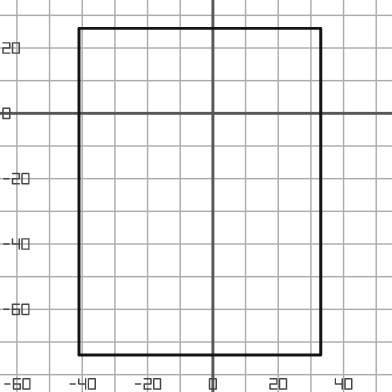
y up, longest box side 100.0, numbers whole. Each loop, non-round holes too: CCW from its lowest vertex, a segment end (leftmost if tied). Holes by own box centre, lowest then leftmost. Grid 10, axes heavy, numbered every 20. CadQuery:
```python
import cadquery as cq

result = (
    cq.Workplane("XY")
    .moveTo(-41.0, -74.0)
    .lineTo(33.0, -74.0)
    .lineTo(33.0, 26.0)
    .lineTo(-41.0, 26.0)
    .close()
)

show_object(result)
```